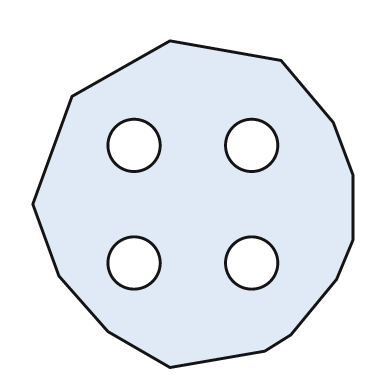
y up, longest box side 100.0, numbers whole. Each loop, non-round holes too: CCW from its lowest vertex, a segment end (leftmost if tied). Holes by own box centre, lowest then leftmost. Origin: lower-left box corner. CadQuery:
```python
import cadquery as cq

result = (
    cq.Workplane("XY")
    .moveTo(42.0, 0.0)
    .lineTo(71.0, 5.0)
    .lineTo(79.0, 10.0)
    .lineTo(93.0, 27.0)
    .lineTo(98.0, 39.0)
    .lineTo(98.0, 59.0)
    .lineTo(92.0, 75.0)
    .lineTo(76.0, 94.0)
    .lineTo(42.0, 100.0)
    .lineTo(12.0, 83.0)
    .lineTo(0.0, 50.0)
    .lineTo(8.0, 28.0)
    .lineTo(23.0, 11.0)
    .close()
    .moveTo(31.0, 32.0)
    .circle(8.0)
    .moveTo(67.0, 32.0)
    .circle(8.0)
    .moveTo(31.0, 68.0)
    .circle(8.0)
    .moveTo(67.0, 68.0)
    .circle(8.0)
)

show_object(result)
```